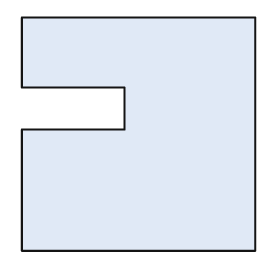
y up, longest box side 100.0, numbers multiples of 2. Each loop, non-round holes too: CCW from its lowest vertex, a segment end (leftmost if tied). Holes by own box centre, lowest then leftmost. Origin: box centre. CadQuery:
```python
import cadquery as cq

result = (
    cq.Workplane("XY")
    .moveTo(-50.0, -50.0)
    .lineTo(50.0, -50.0)
    .lineTo(50.0, 50.0)
    .lineTo(-50.0, 50.0)
    .lineTo(-50.0, 20.0)
    .lineTo(-6.0, 20.0)
    .lineTo(-6.0, 2.0)
    .lineTo(-50.0, 2.0)
    .close()
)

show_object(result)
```